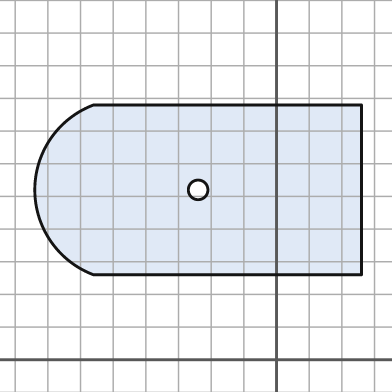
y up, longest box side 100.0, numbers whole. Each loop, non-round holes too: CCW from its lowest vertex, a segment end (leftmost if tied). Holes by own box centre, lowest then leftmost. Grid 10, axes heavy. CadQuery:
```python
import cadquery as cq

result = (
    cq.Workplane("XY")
    .moveTo(-56.0, 26.0)
    .lineTo(26.0, 26.0)
    .lineTo(26.0, 78.0)
    .lineTo(-56.0, 78.0)
    .threePointArc((-74.0, 52.0), (-56.0, 26.0))
    .close()
    .moveTo(-24.0, 52.0)
    .circle(3.0)
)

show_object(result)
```